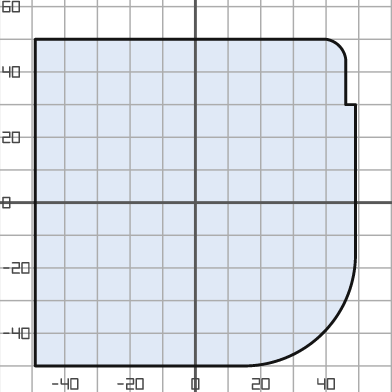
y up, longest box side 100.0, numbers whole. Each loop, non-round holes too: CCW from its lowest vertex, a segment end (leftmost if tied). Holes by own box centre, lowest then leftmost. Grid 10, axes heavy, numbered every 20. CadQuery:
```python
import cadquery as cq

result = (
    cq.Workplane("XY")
    .moveTo(-49.0, -50.0)
    .lineTo(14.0, -50.0)
    .threePointArc((39.0, -40.0), (49.0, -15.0))
    .lineTo(49.0, 30.0)
    .lineTo(46.0, 30.0)
    .lineTo(46.0, 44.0)
    .threePointArc((44.0, 48.0), (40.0, 50.0))
    .lineTo(-49.0, 50.0)
    .close()
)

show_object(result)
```